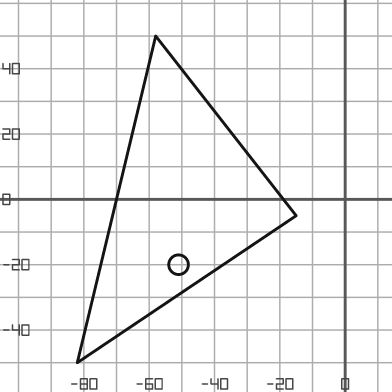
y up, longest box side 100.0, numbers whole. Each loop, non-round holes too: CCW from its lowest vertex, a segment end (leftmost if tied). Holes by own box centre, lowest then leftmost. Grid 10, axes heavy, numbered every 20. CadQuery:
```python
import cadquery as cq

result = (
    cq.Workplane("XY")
    .moveTo(-82.0, -50.0)
    .lineTo(-15.0, -5.0)
    .lineTo(-58.0, 50.0)
    .close()
    .moveTo(-51.0, -20.0)
    .circle(3.0)
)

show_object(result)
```